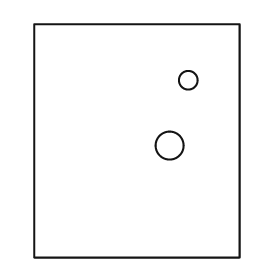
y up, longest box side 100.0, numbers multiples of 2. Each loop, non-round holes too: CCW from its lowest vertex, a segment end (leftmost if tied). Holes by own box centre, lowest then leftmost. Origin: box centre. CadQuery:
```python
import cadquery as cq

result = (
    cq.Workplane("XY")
    .moveTo(-44.0, -50.0)
    .lineTo(44.0, -50.0)
    .lineTo(44.0, 50.0)
    .lineTo(-44.0, 50.0)
    .close()
    .moveTo(14.0, -2.0)
    .circle(6.0)
    .moveTo(22.0, 26.0)
    .circle(4.0)
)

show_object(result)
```